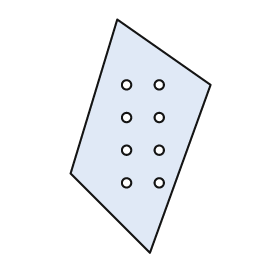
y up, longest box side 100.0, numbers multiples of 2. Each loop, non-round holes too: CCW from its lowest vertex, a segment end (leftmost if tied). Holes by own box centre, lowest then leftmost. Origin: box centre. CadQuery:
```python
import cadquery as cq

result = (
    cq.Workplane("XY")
    .moveTo(4.0, -50.0)
    .lineTo(30.0, 22.0)
    .lineTo(-10.0, 50.0)
    .lineTo(-30.0, -16.0)
    .close()
    .moveTo(-6.0, -20.0)
    .circle(2.0)
    .moveTo(8.0, -20.0)
    .circle(2.0)
    .moveTo(-6.0, -6.0)
    .circle(2.0)
    .moveTo(8.0, -6.0)
    .circle(2.0)
    .moveTo(-6.0, 8.0)
    .circle(2.0)
    .moveTo(8.0, 8.0)
    .circle(2.0)
    .moveTo(-6.0, 22.0)
    .circle(2.0)
    .moveTo(8.0, 22.0)
    .circle(2.0)
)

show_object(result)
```